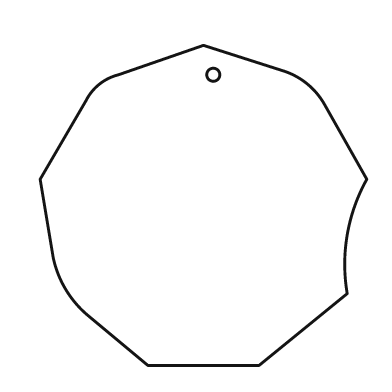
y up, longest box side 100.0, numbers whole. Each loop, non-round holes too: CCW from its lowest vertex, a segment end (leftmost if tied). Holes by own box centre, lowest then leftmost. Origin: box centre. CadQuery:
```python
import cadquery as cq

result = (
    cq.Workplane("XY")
    .moveTo(-17.0, -49.0)
    .lineTo(17.0, -49.0)
    .lineTo(44.0, -27.0)
    .threePointArc((44.0, -9.0), (50.0, 8.0))
    .lineTo(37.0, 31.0)
    .threePointArc((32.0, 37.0), (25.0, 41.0))
    .lineTo(0.0, 49.0)
    .lineTo(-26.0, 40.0)
    .threePointArc((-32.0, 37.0), (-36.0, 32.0))
    .lineTo(-50.0, 8.0)
    .lineTo(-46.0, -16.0)
    .threePointArc((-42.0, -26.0), (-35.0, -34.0))
    .close()
    .moveTo(3.0, 40.0)
    .circle(2.0)
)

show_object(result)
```